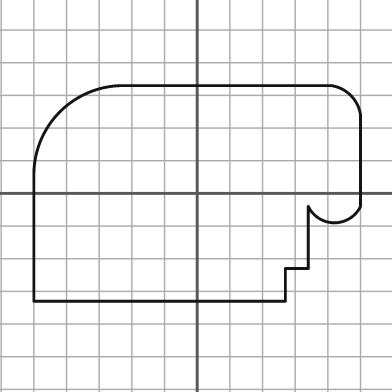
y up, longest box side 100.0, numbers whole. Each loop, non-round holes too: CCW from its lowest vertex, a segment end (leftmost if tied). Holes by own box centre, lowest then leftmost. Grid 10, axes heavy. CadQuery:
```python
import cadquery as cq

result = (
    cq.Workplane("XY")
    .moveTo(-50.0, -33.0)
    .lineTo(27.0, -33.0)
    .lineTo(27.0, -23.0)
    .lineTo(34.0, -23.0)
    .lineTo(34.0, -4.0)
    .threePointArc((42.0, -9.0), (50.0, -4.0))
    .lineTo(50.0, 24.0)
    .threePointArc((47.0, 30.0), (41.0, 33.0))
    .lineTo(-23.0, 33.0)
    .threePointArc((-42.0, 25.0), (-50.0, 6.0))
    .close()
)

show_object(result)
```